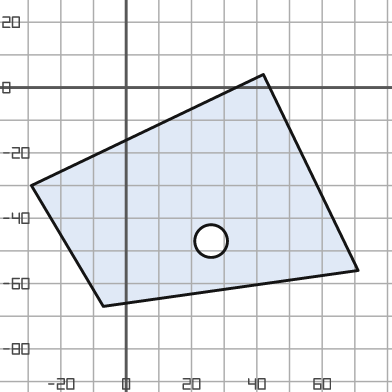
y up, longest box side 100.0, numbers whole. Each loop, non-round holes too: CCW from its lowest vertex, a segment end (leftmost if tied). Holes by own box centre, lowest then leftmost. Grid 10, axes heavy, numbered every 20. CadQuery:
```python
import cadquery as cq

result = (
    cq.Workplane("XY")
    .moveTo(-7.0, -67.0)
    .lineTo(71.0, -56.0)
    .lineTo(42.0, 4.0)
    .lineTo(-29.0, -30.0)
    .close()
    .moveTo(26.0, -47.0)
    .circle(5.0)
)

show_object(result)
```